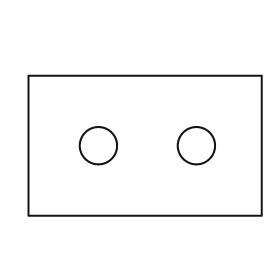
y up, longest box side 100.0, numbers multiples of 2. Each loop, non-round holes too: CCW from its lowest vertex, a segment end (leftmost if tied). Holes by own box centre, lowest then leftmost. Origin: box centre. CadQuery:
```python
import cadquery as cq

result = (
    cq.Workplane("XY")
    .moveTo(-50.0, -30.0)
    .lineTo(50.0, -30.0)
    .lineTo(50.0, 30.0)
    .lineTo(-50.0, 30.0)
    .close()
    .moveTo(-20.0, 0.0)
    .circle(8.0)
    .moveTo(22.0, 0.0)
    .circle(8.0)
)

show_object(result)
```